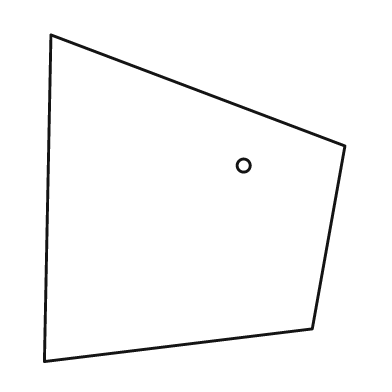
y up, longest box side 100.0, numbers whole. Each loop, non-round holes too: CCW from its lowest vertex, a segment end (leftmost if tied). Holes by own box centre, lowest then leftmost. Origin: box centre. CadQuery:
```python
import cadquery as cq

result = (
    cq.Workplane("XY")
    .moveTo(-46.0, -50.0)
    .lineTo(36.0, -40.0)
    .lineTo(46.0, 16.0)
    .lineTo(-44.0, 50.0)
    .close()
    .moveTo(15.0, 10.0)
    .circle(2.0)
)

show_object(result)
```